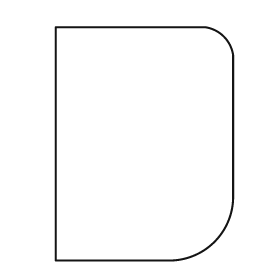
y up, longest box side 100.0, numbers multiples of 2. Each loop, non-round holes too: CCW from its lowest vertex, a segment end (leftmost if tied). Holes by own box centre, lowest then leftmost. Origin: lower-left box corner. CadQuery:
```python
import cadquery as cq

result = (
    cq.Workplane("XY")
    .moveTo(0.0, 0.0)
    .lineTo(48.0, 0.0)
    .threePointArc((68.0, 8.0), (76.0, 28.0))
    .lineTo(76.0, 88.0)
    .threePointArc((72.0, 96.0), (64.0, 100.0))
    .lineTo(0.0, 100.0)
    .close()
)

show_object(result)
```